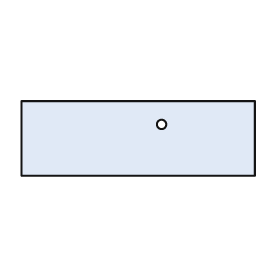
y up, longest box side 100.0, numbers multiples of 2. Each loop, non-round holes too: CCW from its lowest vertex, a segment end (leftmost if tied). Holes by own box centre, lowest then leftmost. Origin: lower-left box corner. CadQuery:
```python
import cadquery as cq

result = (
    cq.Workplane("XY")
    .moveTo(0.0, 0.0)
    .lineTo(100.0, 0.0)
    .lineTo(100.0, 32.0)
    .lineTo(0.0, 32.0)
    .close()
    .moveTo(60.0, 22.0)
    .circle(2.0)
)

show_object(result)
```